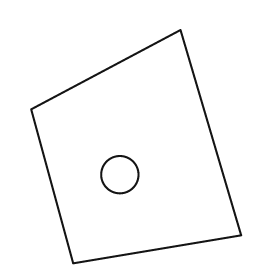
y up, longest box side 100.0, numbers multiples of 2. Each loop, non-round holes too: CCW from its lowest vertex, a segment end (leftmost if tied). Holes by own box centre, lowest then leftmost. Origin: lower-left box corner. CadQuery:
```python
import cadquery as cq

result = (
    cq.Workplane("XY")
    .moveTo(18.0, 0.0)
    .lineTo(90.0, 12.0)
    .lineTo(64.0, 100.0)
    .lineTo(0.0, 66.0)
    .close()
    .moveTo(38.0, 38.0)
    .circle(8.0)
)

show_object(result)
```